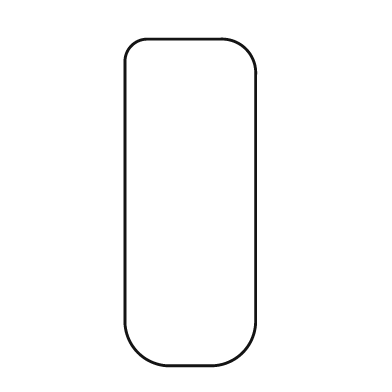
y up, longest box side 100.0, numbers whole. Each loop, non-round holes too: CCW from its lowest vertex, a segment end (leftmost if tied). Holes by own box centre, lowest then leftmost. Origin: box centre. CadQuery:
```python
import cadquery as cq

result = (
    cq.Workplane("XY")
    .moveTo(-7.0, -50.0)
    .lineTo(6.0, -50.0)
    .threePointArc((16.0, -46.0), (20.0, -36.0))
    .lineTo(20.0, 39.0)
    .threePointArc((17.0, 47.0), (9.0, 50.0))
    .lineTo(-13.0, 50.0)
    .threePointArc((-18.0, 48.0), (-20.0, 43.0))
    .lineTo(-20.0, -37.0)
    .threePointArc((-16.0, -46.0), (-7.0, -50.0))
    .close()
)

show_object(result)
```